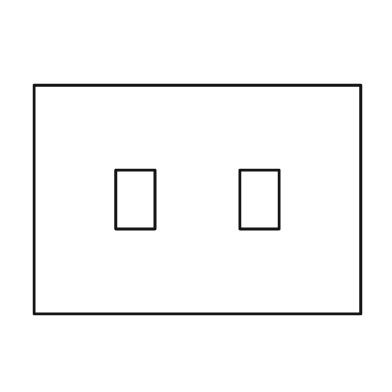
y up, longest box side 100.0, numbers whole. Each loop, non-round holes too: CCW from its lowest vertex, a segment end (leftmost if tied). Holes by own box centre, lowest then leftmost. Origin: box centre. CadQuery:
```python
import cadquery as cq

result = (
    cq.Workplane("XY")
    .moveTo(-50.0, -35.0)
    .lineTo(50.0, -35.0)
    .lineTo(50.0, 35.0)
    .lineTo(-50.0, 35.0)
    .close()
    .moveTo(-25.0, -9.0)
    .lineTo(-13.0, -9.0)
    .lineTo(-13.0, 9.0)
    .lineTo(-25.0, 9.0)
    .close()
    .moveTo(13.0, -9.0)
    .lineTo(25.0, -9.0)
    .lineTo(25.0, 9.0)
    .lineTo(13.0, 9.0)
    .close()
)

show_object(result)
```